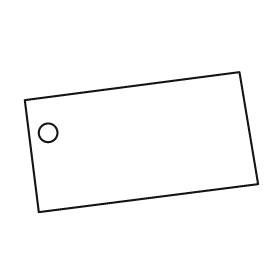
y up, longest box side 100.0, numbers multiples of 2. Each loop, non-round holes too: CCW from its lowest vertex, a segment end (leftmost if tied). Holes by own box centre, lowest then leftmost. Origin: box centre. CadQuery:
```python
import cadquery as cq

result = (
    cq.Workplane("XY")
    .moveTo(-44.0, -30.0)
    .lineTo(50.0, -18.0)
    .lineTo(42.0, 30.0)
    .lineTo(-50.0, 18.0)
    .close()
    .moveTo(-40.0, 4.0)
    .circle(4.0)
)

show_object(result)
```